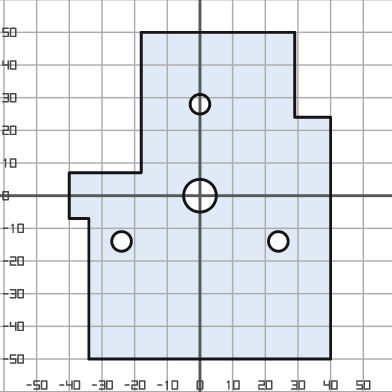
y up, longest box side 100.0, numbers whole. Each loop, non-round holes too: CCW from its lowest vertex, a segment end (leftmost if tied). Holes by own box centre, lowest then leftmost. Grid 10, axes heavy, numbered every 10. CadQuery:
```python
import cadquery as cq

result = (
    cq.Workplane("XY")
    .moveTo(-34.0, -50.0)
    .lineTo(40.0, -50.0)
    .lineTo(40.0, 24.0)
    .lineTo(29.0, 24.0)
    .lineTo(29.0, 50.0)
    .lineTo(-18.0, 50.0)
    .lineTo(-18.0, 7.0)
    .lineTo(-40.0, 7.0)
    .lineTo(-40.0, -7.0)
    .lineTo(-34.0, -7.0)
    .close()
    .moveTo(-24.0, -14.0)
    .circle(3.0)
    .moveTo(24.0, -14.0)
    .circle(3.0)
    .moveTo(0.0, 0.0)
    .circle(5.0)
    .moveTo(0.0, 28.0)
    .circle(3.0)
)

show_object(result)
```